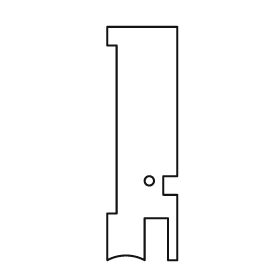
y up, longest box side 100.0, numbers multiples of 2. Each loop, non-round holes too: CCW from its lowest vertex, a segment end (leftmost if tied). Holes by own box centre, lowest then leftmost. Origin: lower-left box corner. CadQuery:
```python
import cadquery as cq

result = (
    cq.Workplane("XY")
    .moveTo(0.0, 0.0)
    .threePointArc((8.0, 2.0), (16.0, 0.0))
    .lineTo(16.0, 18.0)
    .lineTo(26.0, 18.0)
    .lineTo(26.0, 0.0)
    .lineTo(30.0, 0.0)
    .lineTo(30.0, 28.0)
    .lineTo(24.0, 28.0)
    .lineTo(24.0, 36.0)
    .lineTo(30.0, 36.0)
    .lineTo(30.0, 100.0)
    .lineTo(0.0, 100.0)
    .lineTo(0.0, 92.0)
    .lineTo(4.0, 92.0)
    .lineTo(4.0, 20.0)
    .lineTo(0.0, 20.0)
    .close()
    .moveTo(18.0, 34.0)
    .circle(2.0)
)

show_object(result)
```